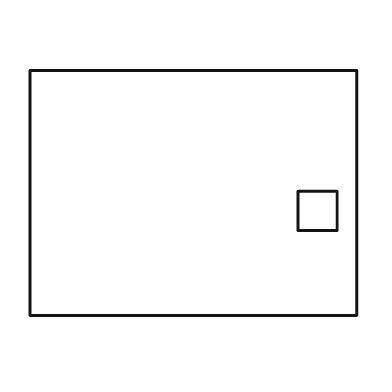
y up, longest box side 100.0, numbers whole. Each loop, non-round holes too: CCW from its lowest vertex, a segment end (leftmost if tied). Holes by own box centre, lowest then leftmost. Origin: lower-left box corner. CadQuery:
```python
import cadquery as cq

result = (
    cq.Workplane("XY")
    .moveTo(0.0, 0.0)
    .lineTo(100.0, 0.0)
    .lineTo(100.0, 75.0)
    .lineTo(0.0, 75.0)
    .close()
    .moveTo(82.0, 26.0)
    .lineTo(94.0, 26.0)
    .lineTo(94.0, 38.0)
    .lineTo(82.0, 38.0)
    .close()
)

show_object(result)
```